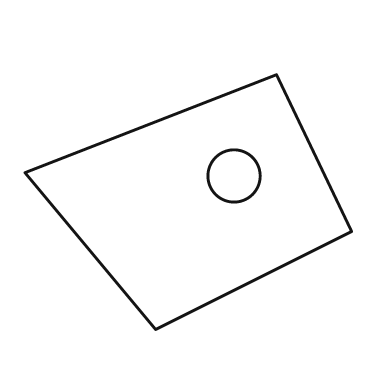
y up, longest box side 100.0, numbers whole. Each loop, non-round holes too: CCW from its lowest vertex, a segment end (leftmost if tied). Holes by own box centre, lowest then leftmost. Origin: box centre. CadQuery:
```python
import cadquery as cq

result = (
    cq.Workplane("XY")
    .moveTo(-10.0, -39.0)
    .lineTo(50.0, -9.0)
    .lineTo(27.0, 39.0)
    .lineTo(-50.0, 9.0)
    .close()
    .moveTo(14.0, 8.0)
    .circle(8.0)
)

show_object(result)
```